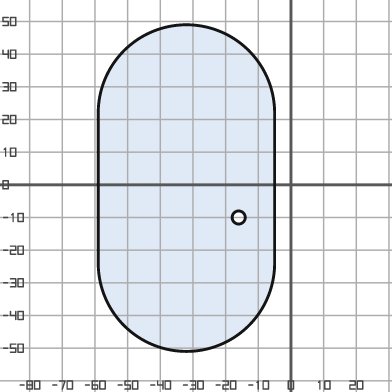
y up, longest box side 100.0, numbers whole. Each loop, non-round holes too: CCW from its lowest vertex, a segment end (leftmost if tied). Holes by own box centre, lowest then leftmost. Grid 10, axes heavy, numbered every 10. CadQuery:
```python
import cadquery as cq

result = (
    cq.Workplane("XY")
    .moveTo(-59.0, -24.0)
    .threePointArc((-32.0, -51.0), (-5.0, -24.0))
    .lineTo(-5.0, 22.0)
    .threePointArc((-32.0, 49.0), (-59.0, 22.0))
    .close()
    .moveTo(-16.0, -10.0)
    .circle(2.0)
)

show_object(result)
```